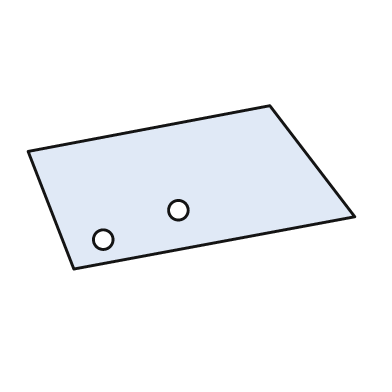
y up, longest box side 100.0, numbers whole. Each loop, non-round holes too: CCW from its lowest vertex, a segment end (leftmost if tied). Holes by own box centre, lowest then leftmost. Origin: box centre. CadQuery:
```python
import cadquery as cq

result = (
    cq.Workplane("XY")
    .moveTo(-36.0, -25.0)
    .lineTo(50.0, -9.0)
    .lineTo(24.0, 25.0)
    .lineTo(-50.0, 11.0)
    .close()
    .moveTo(-27.0, -16.0)
    .circle(3.0)
    .moveTo(-4.0, -7.0)
    .circle(3.0)
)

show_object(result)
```